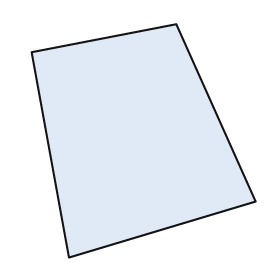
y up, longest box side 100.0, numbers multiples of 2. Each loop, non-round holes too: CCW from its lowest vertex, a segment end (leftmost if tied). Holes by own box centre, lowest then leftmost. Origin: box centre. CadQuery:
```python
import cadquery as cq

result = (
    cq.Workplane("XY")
    .moveTo(-32.0, -50.0)
    .lineTo(48.0, -26.0)
    .lineTo(14.0, 50.0)
    .lineTo(-48.0, 38.0)
    .close()
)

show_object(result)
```